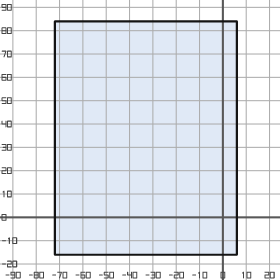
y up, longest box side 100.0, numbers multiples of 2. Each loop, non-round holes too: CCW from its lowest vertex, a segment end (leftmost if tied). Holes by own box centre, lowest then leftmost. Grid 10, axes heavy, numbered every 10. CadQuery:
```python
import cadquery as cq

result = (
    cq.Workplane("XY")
    .moveTo(-72.0, -16.0)
    .lineTo(6.0, -16.0)
    .lineTo(6.0, 84.0)
    .lineTo(-72.0, 84.0)
    .close()
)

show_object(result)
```